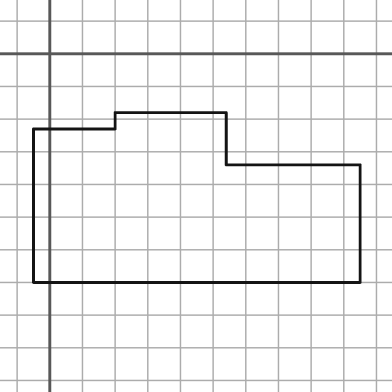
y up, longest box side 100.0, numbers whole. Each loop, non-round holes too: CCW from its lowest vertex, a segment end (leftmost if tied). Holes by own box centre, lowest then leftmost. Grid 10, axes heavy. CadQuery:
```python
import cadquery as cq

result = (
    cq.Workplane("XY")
    .moveTo(-5.0, -70.0)
    .lineTo(95.0, -70.0)
    .lineTo(95.0, -34.0)
    .lineTo(54.0, -34.0)
    .lineTo(54.0, -18.0)
    .lineTo(20.0, -18.0)
    .lineTo(20.0, -23.0)
    .lineTo(-5.0, -23.0)
    .close()
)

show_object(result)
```